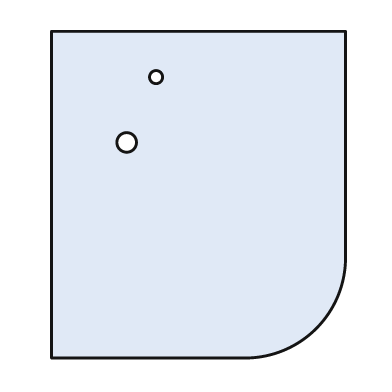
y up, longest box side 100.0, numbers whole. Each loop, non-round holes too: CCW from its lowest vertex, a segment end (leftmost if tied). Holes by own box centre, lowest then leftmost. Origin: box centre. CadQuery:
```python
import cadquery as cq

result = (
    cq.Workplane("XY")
    .moveTo(-45.0, -50.0)
    .lineTo(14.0, -50.0)
    .threePointArc((36.0, -41.0), (45.0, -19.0))
    .lineTo(45.0, 50.0)
    .lineTo(-45.0, 50.0)
    .close()
    .moveTo(-22.0, 16.0)
    .circle(3.0)
    .moveTo(-13.0, 36.0)
    .circle(2.0)
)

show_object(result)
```